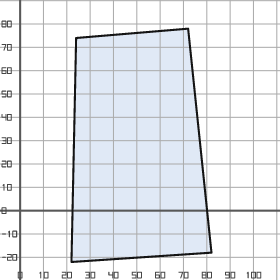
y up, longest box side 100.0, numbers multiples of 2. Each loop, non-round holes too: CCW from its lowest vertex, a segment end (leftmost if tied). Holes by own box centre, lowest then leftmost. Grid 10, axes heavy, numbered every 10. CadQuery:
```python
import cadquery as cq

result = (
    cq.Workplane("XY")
    .moveTo(22.0, -22.0)
    .lineTo(82.0, -18.0)
    .lineTo(72.0, 78.0)
    .lineTo(24.0, 74.0)
    .close()
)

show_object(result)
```